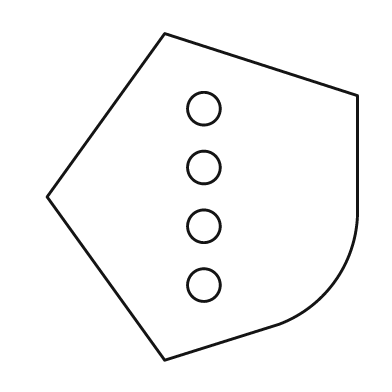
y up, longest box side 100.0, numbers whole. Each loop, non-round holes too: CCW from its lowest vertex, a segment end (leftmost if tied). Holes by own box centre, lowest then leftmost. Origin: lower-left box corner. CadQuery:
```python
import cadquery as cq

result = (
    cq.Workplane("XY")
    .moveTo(36.0, 0.0)
    .lineTo(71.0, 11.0)
    .threePointArc((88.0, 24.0), (95.0, 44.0))
    .lineTo(95.0, 81.0)
    .lineTo(36.0, 100.0)
    .lineTo(0.0, 50.0)
    .close()
    .moveTo(48.0, 23.0)
    .circle(5.0)
    .moveTo(48.0, 41.0)
    .circle(5.0)
    .moveTo(48.0, 59.0)
    .circle(5.0)
    .moveTo(48.0, 77.0)
    .circle(5.0)
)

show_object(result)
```